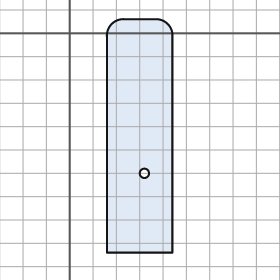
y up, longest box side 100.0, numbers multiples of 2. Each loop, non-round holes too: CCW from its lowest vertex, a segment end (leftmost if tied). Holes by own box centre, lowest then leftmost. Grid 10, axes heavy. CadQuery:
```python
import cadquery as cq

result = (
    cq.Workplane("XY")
    .moveTo(16.0, -94.0)
    .lineTo(44.0, -94.0)
    .lineTo(44.0, 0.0)
    .threePointArc((42.0, 4.0), (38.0, 6.0))
    .lineTo(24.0, 6.0)
    .threePointArc((18.0, 4.0), (16.0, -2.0))
    .close()
    .moveTo(32.0, -60.0)
    .circle(2.0)
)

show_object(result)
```